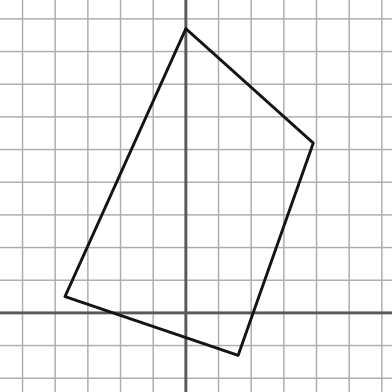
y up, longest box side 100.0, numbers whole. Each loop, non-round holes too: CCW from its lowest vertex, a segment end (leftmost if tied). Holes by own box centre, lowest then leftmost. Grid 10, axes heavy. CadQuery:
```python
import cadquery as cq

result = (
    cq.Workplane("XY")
    .moveTo(16.0, -13.0)
    .lineTo(39.0, 52.0)
    .lineTo(0.0, 87.0)
    .lineTo(-37.0, 5.0)
    .close()
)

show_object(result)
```